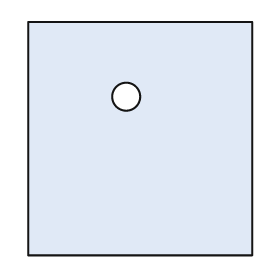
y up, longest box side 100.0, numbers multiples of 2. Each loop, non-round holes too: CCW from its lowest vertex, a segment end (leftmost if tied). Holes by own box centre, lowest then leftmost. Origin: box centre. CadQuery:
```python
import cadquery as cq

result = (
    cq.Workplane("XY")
    .moveTo(-48.0, -50.0)
    .lineTo(48.0, -50.0)
    .lineTo(48.0, 50.0)
    .lineTo(-48.0, 50.0)
    .close()
    .moveTo(-6.0, 18.0)
    .circle(6.0)
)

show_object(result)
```